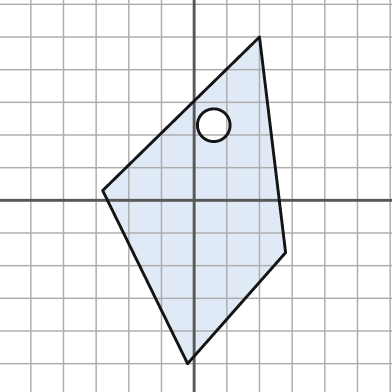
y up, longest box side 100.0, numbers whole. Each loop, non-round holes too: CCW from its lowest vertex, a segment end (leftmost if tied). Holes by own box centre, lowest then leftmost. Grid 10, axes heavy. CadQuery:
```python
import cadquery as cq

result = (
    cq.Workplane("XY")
    .moveTo(-2.0, -50.0)
    .lineTo(28.0, -16.0)
    .lineTo(20.0, 50.0)
    .lineTo(-28.0, 3.0)
    .close()
    .moveTo(6.0, 23.0)
    .circle(5.0)
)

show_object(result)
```